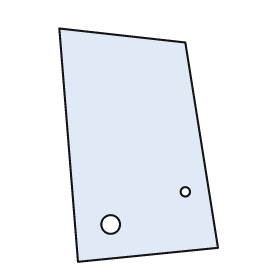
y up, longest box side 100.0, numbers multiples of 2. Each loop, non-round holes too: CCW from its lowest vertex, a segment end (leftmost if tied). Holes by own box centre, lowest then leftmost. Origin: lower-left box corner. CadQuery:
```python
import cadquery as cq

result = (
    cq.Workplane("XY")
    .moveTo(8.0, 0.0)
    .lineTo(68.0, 6.0)
    .lineTo(54.0, 94.0)
    .lineTo(0.0, 100.0)
    .close()
    .moveTo(22.0, 16.0)
    .circle(4.0)
    .moveTo(54.0, 30.0)
    .circle(2.0)
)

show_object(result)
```